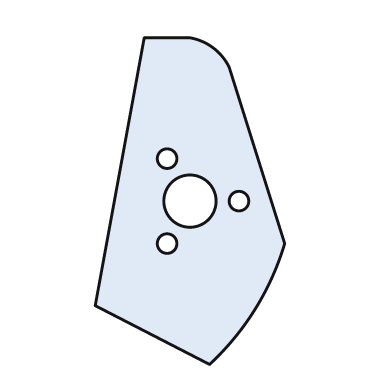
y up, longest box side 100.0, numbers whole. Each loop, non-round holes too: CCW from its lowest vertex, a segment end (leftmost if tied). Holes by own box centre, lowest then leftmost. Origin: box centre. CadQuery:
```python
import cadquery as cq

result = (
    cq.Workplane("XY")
    .moveTo(6.0, -50.0)
    .threePointArc((20.0, -33.0), (29.0, -13.0))
    .lineTo(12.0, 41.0)
    .threePointArc((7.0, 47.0), (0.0, 50.0))
    .lineTo(-14.0, 50.0)
    .lineTo(-29.0, -32.0)
    .close()
    .moveTo(-7.0, -13.0)
    .circle(3.0)
    .moveTo(0.0, 0.0)
    .circle(8.0)
    .moveTo(15.0, 0.0)
    .circle(3.0)
    .moveTo(-7.0, 13.0)
    .circle(3.0)
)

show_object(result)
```